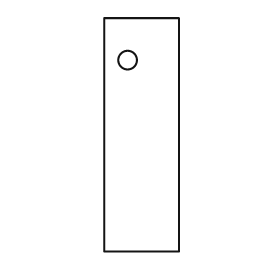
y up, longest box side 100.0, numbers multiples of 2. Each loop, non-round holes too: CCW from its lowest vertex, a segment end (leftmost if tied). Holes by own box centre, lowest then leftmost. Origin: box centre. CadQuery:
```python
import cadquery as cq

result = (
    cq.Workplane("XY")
    .moveTo(-16.0, -50.0)
    .lineTo(16.0, -50.0)
    .lineTo(16.0, 50.0)
    .lineTo(-16.0, 50.0)
    .close()
    .moveTo(-6.0, 32.0)
    .circle(4.0)
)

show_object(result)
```